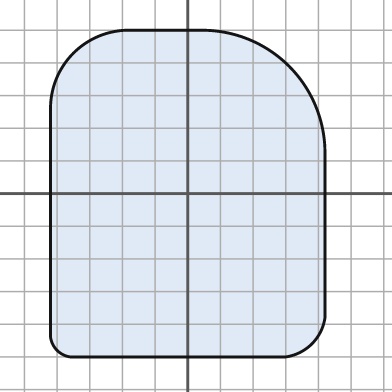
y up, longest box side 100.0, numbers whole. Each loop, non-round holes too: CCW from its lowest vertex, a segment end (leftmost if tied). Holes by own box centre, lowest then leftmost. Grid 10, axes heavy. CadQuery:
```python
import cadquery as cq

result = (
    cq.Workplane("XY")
    .moveTo(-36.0, -50.0)
    .lineTo(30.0, -50.0)
    .threePointArc((38.0, -46.0), (42.0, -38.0))
    .lineTo(42.0, 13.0)
    .threePointArc((31.0, 39.0), (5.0, 50.0))
    .lineTo(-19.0, 50.0)
    .threePointArc((-35.0, 43.0), (-42.0, 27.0))
    .lineTo(-42.0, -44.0)
    .threePointArc((-40.0, -48.0), (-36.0, -50.0))
    .close()
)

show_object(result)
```